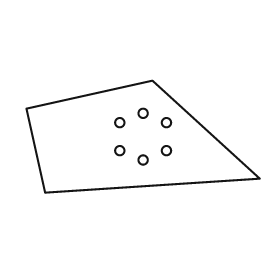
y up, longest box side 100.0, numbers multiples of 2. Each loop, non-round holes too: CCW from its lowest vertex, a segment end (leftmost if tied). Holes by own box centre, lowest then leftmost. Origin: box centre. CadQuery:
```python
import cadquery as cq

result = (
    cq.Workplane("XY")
    .moveTo(-42.0, -24.0)
    .lineTo(50.0, -18.0)
    .lineTo(4.0, 24.0)
    .lineTo(-50.0, 12.0)
    .close()
    .moveTo(0.0, -10.0)
    .circle(2.0)
    .moveTo(-10.0, -6.0)
    .circle(2.0)
    .moveTo(10.0, -6.0)
    .circle(2.0)
    .moveTo(-10.0, 6.0)
    .circle(2.0)
    .moveTo(10.0, 6.0)
    .circle(2.0)
    .moveTo(0.0, 10.0)
    .circle(2.0)
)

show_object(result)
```